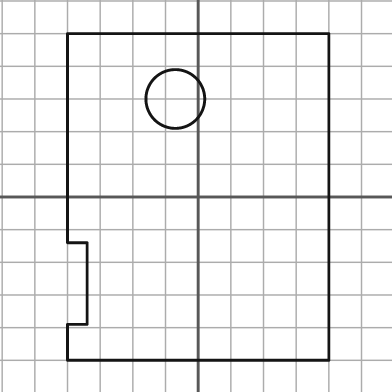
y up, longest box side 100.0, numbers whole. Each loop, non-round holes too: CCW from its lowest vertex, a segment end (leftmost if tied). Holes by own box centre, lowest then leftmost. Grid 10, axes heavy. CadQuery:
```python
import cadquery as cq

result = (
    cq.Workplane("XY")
    .moveTo(-40.0, -50.0)
    .lineTo(40.0, -50.0)
    .lineTo(40.0, 50.0)
    .lineTo(-40.0, 50.0)
    .lineTo(-40.0, -14.0)
    .lineTo(-34.0, -14.0)
    .lineTo(-34.0, -39.0)
    .lineTo(-40.0, -39.0)
    .close()
    .moveTo(-7.0, 30.0)
    .circle(9.0)
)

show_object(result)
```